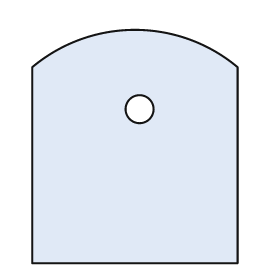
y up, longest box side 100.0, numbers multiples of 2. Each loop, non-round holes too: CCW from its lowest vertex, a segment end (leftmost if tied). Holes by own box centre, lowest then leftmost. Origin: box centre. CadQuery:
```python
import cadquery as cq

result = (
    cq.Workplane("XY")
    .moveTo(-44.0, -50.0)
    .lineTo(44.0, -50.0)
    .lineTo(44.0, 34.0)
    .threePointArc((0.0, 50.0), (-44.0, 34.0))
    .close()
    .moveTo(2.0, 16.0)
    .circle(6.0)
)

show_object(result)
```